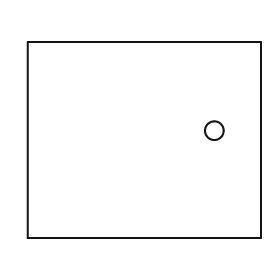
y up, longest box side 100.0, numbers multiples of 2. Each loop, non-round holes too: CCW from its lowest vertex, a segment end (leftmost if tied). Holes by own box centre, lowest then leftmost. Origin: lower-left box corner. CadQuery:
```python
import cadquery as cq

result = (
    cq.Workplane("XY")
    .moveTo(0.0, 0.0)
    .lineTo(100.0, 0.0)
    .lineTo(100.0, 84.0)
    .lineTo(0.0, 84.0)
    .close()
    .moveTo(80.0, 46.0)
    .circle(4.0)
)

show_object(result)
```